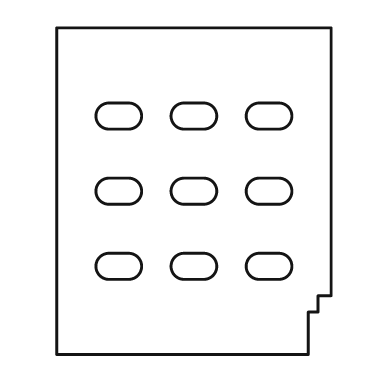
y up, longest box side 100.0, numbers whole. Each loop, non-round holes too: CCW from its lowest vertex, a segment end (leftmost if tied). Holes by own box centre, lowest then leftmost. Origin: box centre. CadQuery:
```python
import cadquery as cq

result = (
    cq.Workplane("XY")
    .moveTo(-42.0, -50.0)
    .lineTo(35.0, -50.0)
    .lineTo(35.0, -37.0)
    .lineTo(38.0, -37.0)
    .lineTo(38.0, -32.0)
    .lineTo(42.0, -32.0)
    .lineTo(42.0, 50.0)
    .lineTo(-42.0, 50.0)
    .close()
    .moveTo(-26.0, -27.0)
    .lineTo(-20.0, -27.0)
    .threePointArc((-16.0, -23.0), (-20.0, -19.0))
    .lineTo(-26.0, -19.0)
    .threePointArc((-30.0, -23.0), (-26.0, -27.0))
    .close()
    .moveTo(-3.0, -27.0)
    .lineTo(3.0, -27.0)
    .threePointArc((7.0, -23.0), (3.0, -19.0))
    .lineTo(-3.0, -19.0)
    .threePointArc((-7.0, -23.0), (-3.0, -27.0))
    .close()
    .moveTo(20.0, -27.0)
    .lineTo(26.0, -27.0)
    .threePointArc((30.0, -23.0), (26.0, -19.0))
    .lineTo(20.0, -19.0)
    .threePointArc((16.0, -23.0), (20.0, -27.0))
    .close()
    .moveTo(-26.0, -4.0)
    .lineTo(-20.0, -4.0)
    .threePointArc((-16.0, 0.0), (-20.0, 4.0))
    .lineTo(-26.0, 4.0)
    .threePointArc((-30.0, 0.0), (-26.0, -4.0))
    .close()
    .moveTo(-3.0, -4.0)
    .lineTo(3.0, -4.0)
    .threePointArc((7.0, 0.0), (3.0, 4.0))
    .lineTo(-3.0, 4.0)
    .threePointArc((-7.0, 0.0), (-3.0, -4.0))
    .close()
    .moveTo(20.0, -4.0)
    .lineTo(26.0, -4.0)
    .threePointArc((30.0, 0.0), (26.0, 4.0))
    .lineTo(20.0, 4.0)
    .threePointArc((16.0, 0.0), (20.0, -4.0))
    .close()
    .moveTo(-26.0, 19.0)
    .lineTo(-20.0, 19.0)
    .threePointArc((-16.0, 23.0), (-20.0, 27.0))
    .lineTo(-26.0, 27.0)
    .threePointArc((-30.0, 23.0), (-26.0, 19.0))
    .close()
    .moveTo(-3.0, 19.0)
    .lineTo(3.0, 19.0)
    .threePointArc((7.0, 23.0), (3.0, 27.0))
    .lineTo(-3.0, 27.0)
    .threePointArc((-7.0, 23.0), (-3.0, 19.0))
    .close()
    .moveTo(20.0, 19.0)
    .lineTo(26.0, 19.0)
    .threePointArc((30.0, 23.0), (26.0, 27.0))
    .lineTo(20.0, 27.0)
    .threePointArc((16.0, 23.0), (20.0, 19.0))
    .close()
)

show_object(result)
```